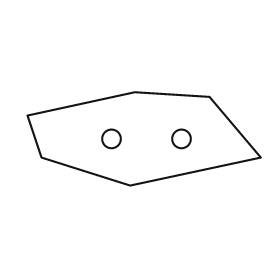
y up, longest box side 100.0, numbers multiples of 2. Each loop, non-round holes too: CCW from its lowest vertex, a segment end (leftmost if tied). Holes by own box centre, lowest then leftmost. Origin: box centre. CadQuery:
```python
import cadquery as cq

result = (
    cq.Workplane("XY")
    .moveTo(-6.0, -20.0)
    .lineTo(50.0, -8.0)
    .lineTo(28.0, 18.0)
    .lineTo(-4.0, 20.0)
    .lineTo(-50.0, 10.0)
    .lineTo(-44.0, -8.0)
    .close()
    .moveTo(-14.0, 0.0)
    .circle(4.0)
    .moveTo(16.0, 0.0)
    .circle(4.0)
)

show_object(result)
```